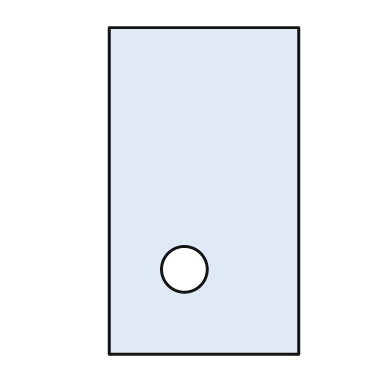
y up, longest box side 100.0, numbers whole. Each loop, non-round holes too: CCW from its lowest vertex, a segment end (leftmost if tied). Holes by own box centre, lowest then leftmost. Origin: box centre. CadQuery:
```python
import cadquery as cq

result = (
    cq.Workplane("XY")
    .moveTo(-29.0, -50.0)
    .lineTo(29.0, -50.0)
    .lineTo(29.0, 50.0)
    .lineTo(-29.0, 50.0)
    .close()
    .moveTo(-6.0, -24.0)
    .circle(7.0)
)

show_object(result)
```